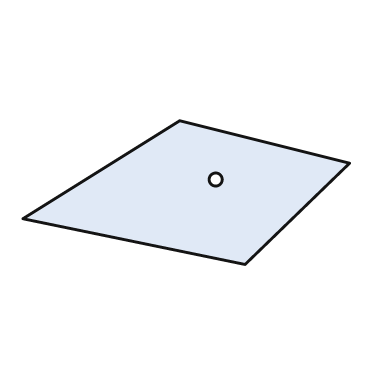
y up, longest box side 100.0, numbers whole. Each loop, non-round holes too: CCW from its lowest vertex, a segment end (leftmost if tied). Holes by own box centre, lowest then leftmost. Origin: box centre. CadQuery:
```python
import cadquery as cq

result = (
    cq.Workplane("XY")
    .moveTo(18.0, -22.0)
    .lineTo(50.0, 9.0)
    .lineTo(-2.0, 22.0)
    .lineTo(-50.0, -8.0)
    .close()
    .moveTo(9.0, 4.0)
    .circle(2.0)
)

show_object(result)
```